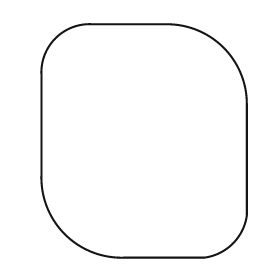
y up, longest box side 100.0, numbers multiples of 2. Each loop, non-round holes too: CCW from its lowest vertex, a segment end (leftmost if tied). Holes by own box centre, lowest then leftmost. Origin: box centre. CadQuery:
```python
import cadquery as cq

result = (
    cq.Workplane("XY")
    .moveTo(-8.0, -50.0)
    .lineTo(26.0, -50.0)
    .threePointArc((38.0, -44.0), (44.0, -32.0))
    .lineTo(44.0, 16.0)
    .threePointArc((34.0, 40.0), (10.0, 50.0))
    .lineTo(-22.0, 50.0)
    .threePointArc((-38.0, 44.0), (-44.0, 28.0))
    .lineTo(-44.0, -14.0)
    .threePointArc((-34.0, -40.0), (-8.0, -50.0))
    .close()
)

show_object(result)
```